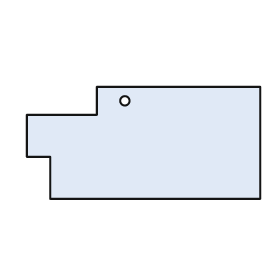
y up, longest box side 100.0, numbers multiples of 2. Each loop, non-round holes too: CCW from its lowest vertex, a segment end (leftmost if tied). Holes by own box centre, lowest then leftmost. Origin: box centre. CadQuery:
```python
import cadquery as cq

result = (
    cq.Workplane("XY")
    .moveTo(-40.0, -24.0)
    .lineTo(50.0, -24.0)
    .lineTo(50.0, 24.0)
    .lineTo(-20.0, 24.0)
    .lineTo(-20.0, 12.0)
    .lineTo(-50.0, 12.0)
    .lineTo(-50.0, -6.0)
    .lineTo(-40.0, -6.0)
    .close()
    .moveTo(-8.0, 18.0)
    .circle(2.0)
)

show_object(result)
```